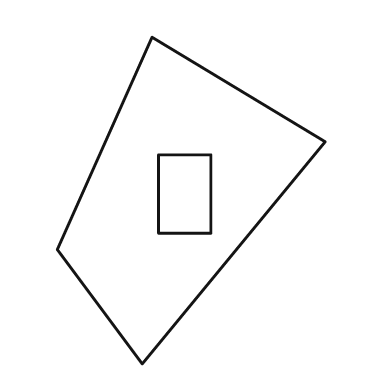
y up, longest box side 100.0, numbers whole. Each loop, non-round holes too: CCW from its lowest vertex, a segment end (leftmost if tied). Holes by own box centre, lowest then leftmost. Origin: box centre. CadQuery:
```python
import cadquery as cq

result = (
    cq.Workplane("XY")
    .moveTo(-15.0, -50.0)
    .lineTo(41.0, 18.0)
    .lineTo(-12.0, 50.0)
    .lineTo(-41.0, -15.0)
    .close()
    .moveTo(-10.0, -10.0)
    .lineTo(6.0, -10.0)
    .lineTo(6.0, 14.0)
    .lineTo(-10.0, 14.0)
    .close()
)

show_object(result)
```